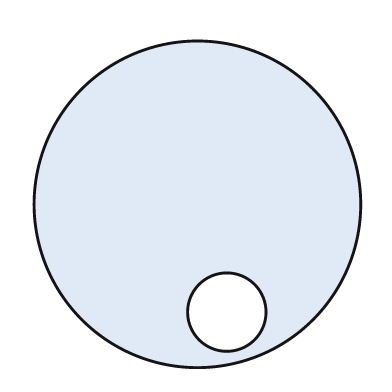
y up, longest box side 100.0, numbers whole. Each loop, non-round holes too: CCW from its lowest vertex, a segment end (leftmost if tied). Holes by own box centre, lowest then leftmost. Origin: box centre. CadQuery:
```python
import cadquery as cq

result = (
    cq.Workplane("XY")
    .moveTo(0.0, 0.0)
    .circle(50.0)
    .moveTo(9.0, -33.0)
    .circle(12.0)
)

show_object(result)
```